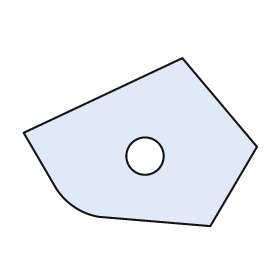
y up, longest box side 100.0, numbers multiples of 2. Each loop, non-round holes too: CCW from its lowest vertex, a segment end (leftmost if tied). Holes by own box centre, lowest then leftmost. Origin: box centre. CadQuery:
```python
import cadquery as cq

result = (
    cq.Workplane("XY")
    .moveTo(30.0, -36.0)
    .lineTo(50.0, -2.0)
    .lineTo(18.0, 36.0)
    .lineTo(-50.0, 4.0)
    .lineTo(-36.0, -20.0)
    .threePointArc((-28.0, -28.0), (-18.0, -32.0))
    .close()
    .moveTo(2.0, -6.0)
    .circle(8.0)
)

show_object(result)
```